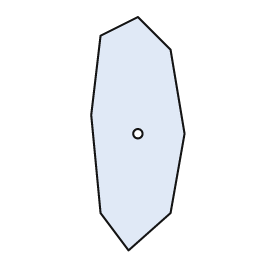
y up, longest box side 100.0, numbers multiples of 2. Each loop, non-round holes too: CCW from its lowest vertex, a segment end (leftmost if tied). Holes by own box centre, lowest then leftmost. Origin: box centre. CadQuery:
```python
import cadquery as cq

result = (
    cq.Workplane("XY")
    .moveTo(-4.0, -50.0)
    .lineTo(14.0, -34.0)
    .lineTo(20.0, 0.0)
    .lineTo(14.0, 36.0)
    .lineTo(0.0, 50.0)
    .lineTo(-16.0, 42.0)
    .lineTo(-20.0, 8.0)
    .lineTo(-16.0, -34.0)
    .close()
    .moveTo(0.0, 0.0)
    .circle(2.0)
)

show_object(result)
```